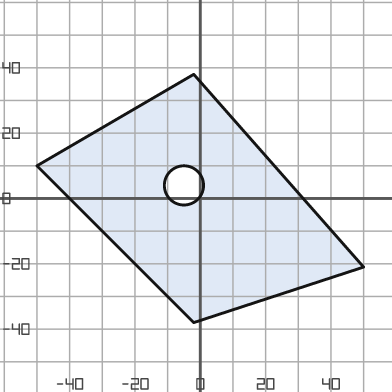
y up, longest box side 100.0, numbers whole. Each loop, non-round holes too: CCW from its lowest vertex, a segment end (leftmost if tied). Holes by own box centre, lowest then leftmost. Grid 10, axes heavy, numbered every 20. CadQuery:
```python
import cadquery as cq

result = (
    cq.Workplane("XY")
    .moveTo(-2.0, -38.0)
    .lineTo(50.0, -21.0)
    .lineTo(-2.0, 38.0)
    .lineTo(-50.0, 10.0)
    .close()
    .moveTo(-5.0, 4.0)
    .circle(6.0)
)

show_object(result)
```